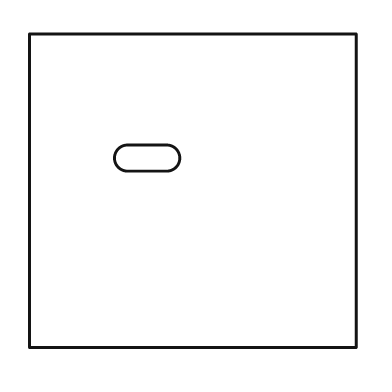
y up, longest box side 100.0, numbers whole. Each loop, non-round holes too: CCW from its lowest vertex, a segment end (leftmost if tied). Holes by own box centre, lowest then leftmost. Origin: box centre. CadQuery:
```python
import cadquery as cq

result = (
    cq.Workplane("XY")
    .moveTo(-50.0, -48.0)
    .lineTo(50.0, -48.0)
    .lineTo(50.0, 48.0)
    .lineTo(-50.0, 48.0)
    .close()
    .moveTo(-20.0, 6.0)
    .lineTo(-8.0, 6.0)
    .threePointArc((-4.0, 10.0), (-8.0, 14.0))
    .lineTo(-20.0, 14.0)
    .threePointArc((-24.0, 10.0), (-20.0, 6.0))
    .close()
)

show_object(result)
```